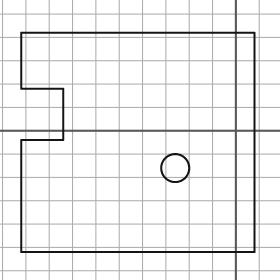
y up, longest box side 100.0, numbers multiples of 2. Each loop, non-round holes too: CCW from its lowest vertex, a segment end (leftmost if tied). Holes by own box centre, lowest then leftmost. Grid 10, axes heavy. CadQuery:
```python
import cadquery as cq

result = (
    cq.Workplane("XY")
    .moveTo(-92.0, -52.0)
    .lineTo(8.0, -52.0)
    .lineTo(8.0, 42.0)
    .lineTo(-92.0, 42.0)
    .lineTo(-92.0, 18.0)
    .lineTo(-74.0, 18.0)
    .lineTo(-74.0, -4.0)
    .lineTo(-92.0, -4.0)
    .close()
    .moveTo(-26.0, -16.0)
    .circle(6.0)
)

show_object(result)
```